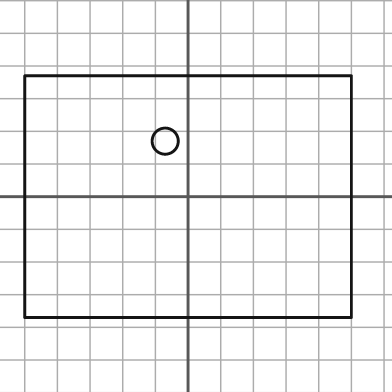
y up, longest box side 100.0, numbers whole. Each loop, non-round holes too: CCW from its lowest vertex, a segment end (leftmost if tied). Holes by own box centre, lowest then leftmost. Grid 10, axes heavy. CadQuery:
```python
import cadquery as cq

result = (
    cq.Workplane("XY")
    .moveTo(-50.0, -37.0)
    .lineTo(50.0, -37.0)
    .lineTo(50.0, 37.0)
    .lineTo(-50.0, 37.0)
    .close()
    .moveTo(-7.0, 17.0)
    .circle(4.0)
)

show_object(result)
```